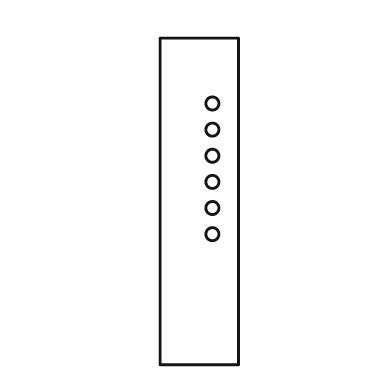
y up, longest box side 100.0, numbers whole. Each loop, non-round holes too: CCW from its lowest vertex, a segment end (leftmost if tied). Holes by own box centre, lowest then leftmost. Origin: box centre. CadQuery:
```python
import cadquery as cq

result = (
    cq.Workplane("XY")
    .moveTo(-12.0, -50.0)
    .lineTo(12.0, -50.0)
    .lineTo(12.0, 50.0)
    .lineTo(-12.0, 50.0)
    .close()
    .moveTo(4.0, -10.0)
    .circle(2.0)
    .moveTo(4.0, -2.0)
    .circle(2.0)
    .moveTo(4.0, 6.0)
    .circle(2.0)
    .moveTo(4.0, 14.0)
    .circle(2.0)
    .moveTo(4.0, 22.0)
    .circle(2.0)
    .moveTo(4.0, 30.0)
    .circle(2.0)
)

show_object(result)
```